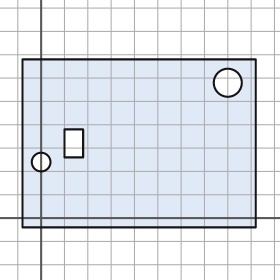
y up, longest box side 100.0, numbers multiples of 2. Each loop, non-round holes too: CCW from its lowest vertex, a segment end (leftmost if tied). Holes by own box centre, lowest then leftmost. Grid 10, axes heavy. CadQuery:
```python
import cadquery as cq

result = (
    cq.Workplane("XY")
    .moveTo(-8.0, -4.0)
    .lineTo(92.0, -4.0)
    .lineTo(92.0, 68.0)
    .lineTo(-8.0, 68.0)
    .close()
    .moveTo(0.0, 24.0)
    .circle(4.0)
    .moveTo(10.0, 26.0)
    .lineTo(18.0, 26.0)
    .lineTo(18.0, 38.0)
    .lineTo(10.0, 38.0)
    .close()
    .moveTo(80.0, 58.0)
    .circle(6.0)
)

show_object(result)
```